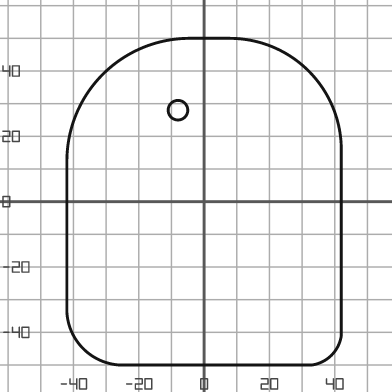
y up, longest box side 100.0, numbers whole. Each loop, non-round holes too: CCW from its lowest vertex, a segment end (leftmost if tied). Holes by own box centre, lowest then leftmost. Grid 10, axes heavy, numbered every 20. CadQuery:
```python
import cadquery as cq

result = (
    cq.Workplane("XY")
    .moveTo(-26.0, -50.0)
    .lineTo(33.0, -50.0)
    .threePointArc((39.0, -47.0), (42.0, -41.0))
    .lineTo(42.0, 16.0)
    .threePointArc((32.0, 40.0), (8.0, 50.0))
    .lineTo(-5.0, 50.0)
    .threePointArc((-31.0, 39.0), (-42.0, 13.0))
    .lineTo(-42.0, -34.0)
    .threePointArc((-37.0, -45.0), (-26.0, -50.0))
    .close()
    .moveTo(-8.0, 28.0)
    .circle(3.0)
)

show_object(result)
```